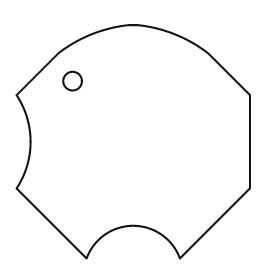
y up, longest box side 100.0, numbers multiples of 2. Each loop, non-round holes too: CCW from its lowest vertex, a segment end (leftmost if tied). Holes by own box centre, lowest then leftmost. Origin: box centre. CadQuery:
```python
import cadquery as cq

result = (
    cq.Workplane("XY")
    .moveTo(-20.0, -50.0)
    .threePointArc((0.0, -36.0), (20.0, -50.0))
    .lineTo(50.0, -20.0)
    .lineTo(50.0, 20.0)
    .lineTo(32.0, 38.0)
    .threePointArc((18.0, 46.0), (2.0, 50.0))
    .lineTo(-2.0, 50.0)
    .threePointArc((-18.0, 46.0), (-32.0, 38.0))
    .lineTo(-50.0, 20.0)
    .threePointArc((-44.0, 0.0), (-50.0, -20.0))
    .close()
    .moveTo(-26.0, 26.0)
    .circle(4.0)
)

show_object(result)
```